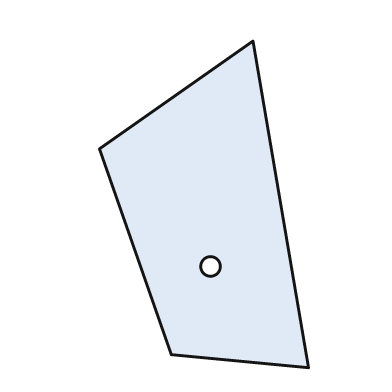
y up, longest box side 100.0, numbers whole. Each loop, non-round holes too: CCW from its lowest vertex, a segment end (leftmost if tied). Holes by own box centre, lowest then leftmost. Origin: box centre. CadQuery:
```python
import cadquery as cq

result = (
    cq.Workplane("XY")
    .moveTo(32.0, -50.0)
    .lineTo(15.0, 50.0)
    .lineTo(-32.0, 17.0)
    .lineTo(-10.0, -46.0)
    .close()
    .moveTo(2.0, -19.0)
    .circle(3.0)
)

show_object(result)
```